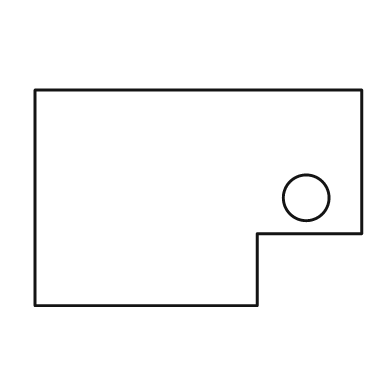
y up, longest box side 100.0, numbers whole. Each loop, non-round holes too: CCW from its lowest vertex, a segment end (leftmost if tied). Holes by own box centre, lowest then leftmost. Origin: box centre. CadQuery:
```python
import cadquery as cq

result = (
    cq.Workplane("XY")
    .moveTo(-50.0, -33.0)
    .lineTo(18.0, -33.0)
    .lineTo(18.0, -11.0)
    .lineTo(50.0, -11.0)
    .lineTo(50.0, 33.0)
    .lineTo(-50.0, 33.0)
    .close()
    .moveTo(33.0, 0.0)
    .circle(7.0)
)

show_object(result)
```